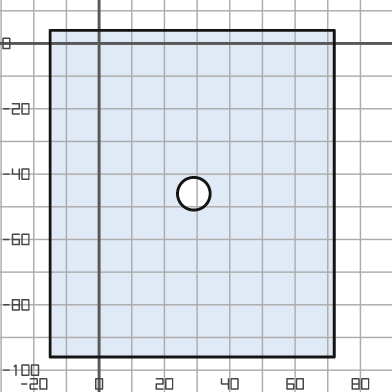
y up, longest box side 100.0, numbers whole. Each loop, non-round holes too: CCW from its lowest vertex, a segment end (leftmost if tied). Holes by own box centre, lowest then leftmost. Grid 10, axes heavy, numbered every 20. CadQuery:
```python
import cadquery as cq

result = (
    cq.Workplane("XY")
    .moveTo(-15.0, -96.0)
    .lineTo(72.0, -96.0)
    .lineTo(72.0, 4.0)
    .lineTo(-15.0, 4.0)
    .close()
    .moveTo(29.0, -46.0)
    .circle(5.0)
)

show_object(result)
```